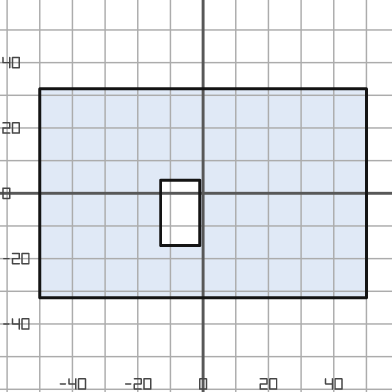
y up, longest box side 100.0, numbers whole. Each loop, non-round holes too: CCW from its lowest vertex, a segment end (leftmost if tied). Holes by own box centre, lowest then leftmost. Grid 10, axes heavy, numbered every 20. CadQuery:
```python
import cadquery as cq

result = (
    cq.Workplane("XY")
    .moveTo(-50.0, -32.0)
    .lineTo(50.0, -32.0)
    .lineTo(50.0, 32.0)
    .lineTo(-50.0, 32.0)
    .close()
    .moveTo(-13.0, -16.0)
    .lineTo(-1.0, -16.0)
    .lineTo(-1.0, 4.0)
    .lineTo(-13.0, 4.0)
    .close()
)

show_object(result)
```